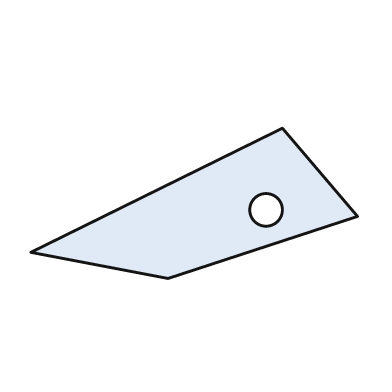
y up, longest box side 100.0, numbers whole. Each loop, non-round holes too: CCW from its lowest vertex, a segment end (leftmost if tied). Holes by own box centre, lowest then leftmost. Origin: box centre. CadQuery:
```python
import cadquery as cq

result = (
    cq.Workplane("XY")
    .moveTo(-8.0, -23.0)
    .lineTo(50.0, -4.0)
    .lineTo(27.0, 23.0)
    .lineTo(-50.0, -15.0)
    .close()
    .moveTo(22.0, -2.0)
    .circle(5.0)
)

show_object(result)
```